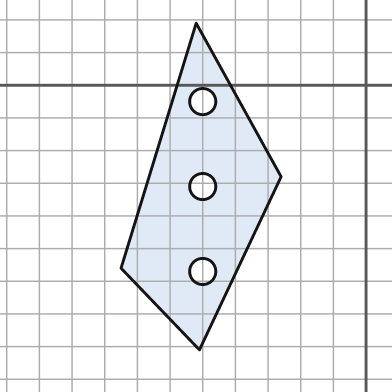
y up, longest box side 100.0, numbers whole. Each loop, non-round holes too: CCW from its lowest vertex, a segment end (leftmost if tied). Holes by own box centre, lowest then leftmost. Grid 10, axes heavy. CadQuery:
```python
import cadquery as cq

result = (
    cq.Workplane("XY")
    .moveTo(-51.0, -81.0)
    .lineTo(-26.0, -28.0)
    .lineTo(-52.0, 19.0)
    .lineTo(-75.0, -56.0)
    .close()
    .moveTo(-50.0, -57.0)
    .circle(4.0)
    .moveTo(-50.0, -31.0)
    .circle(4.0)
    .moveTo(-50.0, -5.0)
    .circle(4.0)
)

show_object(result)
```